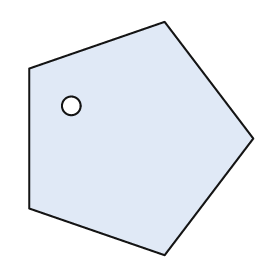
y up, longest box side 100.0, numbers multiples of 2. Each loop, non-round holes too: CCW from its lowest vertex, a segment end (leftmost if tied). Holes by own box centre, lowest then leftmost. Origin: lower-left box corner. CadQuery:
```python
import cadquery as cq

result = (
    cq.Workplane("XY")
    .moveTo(58.0, 0.0)
    .lineTo(96.0, 50.0)
    .lineTo(58.0, 100.0)
    .lineTo(0.0, 80.0)
    .lineTo(0.0, 20.0)
    .close()
    .moveTo(18.0, 64.0)
    .circle(4.0)
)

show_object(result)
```